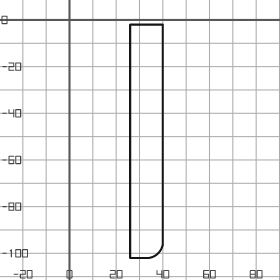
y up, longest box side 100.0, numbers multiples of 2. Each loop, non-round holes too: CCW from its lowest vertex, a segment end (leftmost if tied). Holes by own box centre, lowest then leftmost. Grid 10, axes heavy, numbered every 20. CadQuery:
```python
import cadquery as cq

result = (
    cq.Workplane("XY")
    .moveTo(26.0, -102.0)
    .lineTo(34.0, -102.0)
    .threePointArc((38.0, -100.0), (40.0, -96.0))
    .lineTo(40.0, -2.0)
    .lineTo(26.0, -2.0)
    .close()
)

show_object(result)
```